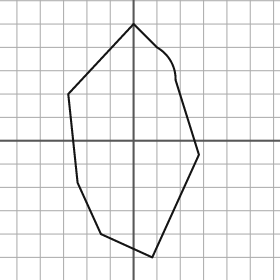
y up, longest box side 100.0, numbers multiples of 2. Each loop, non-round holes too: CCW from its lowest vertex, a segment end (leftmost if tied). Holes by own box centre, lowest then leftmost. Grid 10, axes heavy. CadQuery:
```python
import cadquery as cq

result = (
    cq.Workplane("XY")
    .moveTo(8.0, -50.0)
    .lineTo(28.0, -6.0)
    .lineTo(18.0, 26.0)
    .threePointArc((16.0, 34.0), (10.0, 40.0))
    .lineTo(0.0, 50.0)
    .lineTo(-28.0, 20.0)
    .lineTo(-24.0, -18.0)
    .lineTo(-14.0, -40.0)
    .close()
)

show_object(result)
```